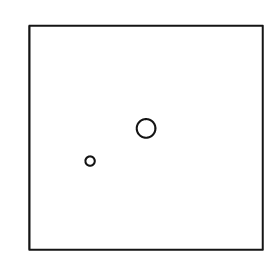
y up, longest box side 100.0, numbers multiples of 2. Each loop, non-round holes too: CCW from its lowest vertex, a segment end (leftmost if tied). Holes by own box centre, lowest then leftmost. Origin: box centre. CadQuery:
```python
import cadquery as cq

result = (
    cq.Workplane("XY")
    .moveTo(-50.0, -48.0)
    .lineTo(50.0, -48.0)
    .lineTo(50.0, 48.0)
    .lineTo(-50.0, 48.0)
    .close()
    .moveTo(-24.0, -10.0)
    .circle(2.0)
    .moveTo(0.0, 4.0)
    .circle(4.0)
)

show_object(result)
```